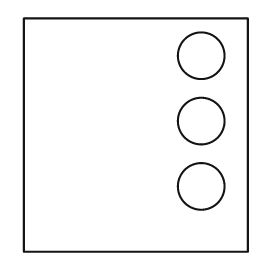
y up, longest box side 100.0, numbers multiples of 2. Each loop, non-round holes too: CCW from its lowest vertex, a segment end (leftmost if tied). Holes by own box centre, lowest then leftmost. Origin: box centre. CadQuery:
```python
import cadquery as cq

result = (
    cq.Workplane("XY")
    .moveTo(-48.0, -50.0)
    .lineTo(48.0, -50.0)
    .lineTo(48.0, 50.0)
    .lineTo(-48.0, 50.0)
    .close()
    .moveTo(28.0, -22.0)
    .circle(10.0)
    .moveTo(28.0, 6.0)
    .circle(10.0)
    .moveTo(28.0, 34.0)
    .circle(10.0)
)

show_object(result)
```